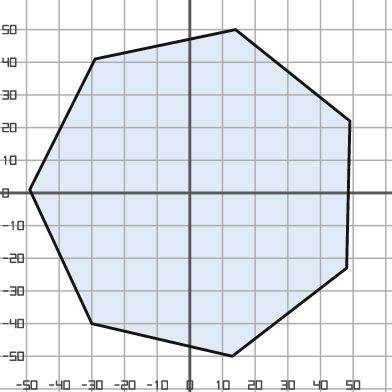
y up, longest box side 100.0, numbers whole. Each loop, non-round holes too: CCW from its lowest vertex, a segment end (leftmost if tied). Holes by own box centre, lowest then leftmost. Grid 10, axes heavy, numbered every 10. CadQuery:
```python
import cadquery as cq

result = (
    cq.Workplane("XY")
    .moveTo(13.0, -50.0)
    .lineTo(48.0, -23.0)
    .lineTo(49.0, 22.0)
    .lineTo(14.0, 50.0)
    .lineTo(-29.0, 41.0)
    .lineTo(-49.0, 1.0)
    .lineTo(-30.0, -40.0)
    .close()
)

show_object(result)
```